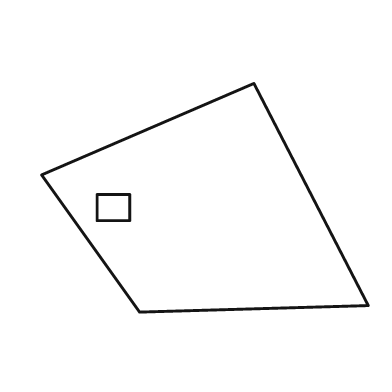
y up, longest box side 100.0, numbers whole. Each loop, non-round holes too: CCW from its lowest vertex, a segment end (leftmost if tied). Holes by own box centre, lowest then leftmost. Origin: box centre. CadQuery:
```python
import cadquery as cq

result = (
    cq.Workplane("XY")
    .moveTo(-20.0, -35.0)
    .lineTo(50.0, -33.0)
    .lineTo(15.0, 35.0)
    .lineTo(-50.0, 7.0)
    .close()
    .moveTo(-33.0, -7.0)
    .lineTo(-23.0, -7.0)
    .lineTo(-23.0, 1.0)
    .lineTo(-33.0, 1.0)
    .close()
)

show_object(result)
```